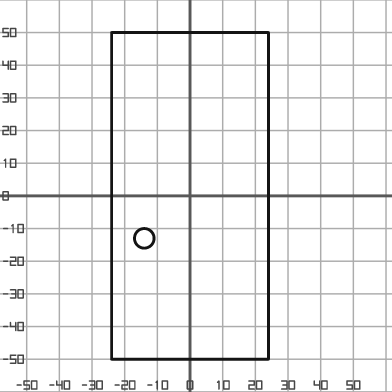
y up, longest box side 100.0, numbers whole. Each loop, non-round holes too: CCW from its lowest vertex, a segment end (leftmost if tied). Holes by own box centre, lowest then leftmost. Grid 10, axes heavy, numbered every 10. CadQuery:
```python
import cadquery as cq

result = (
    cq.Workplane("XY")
    .moveTo(-24.0, -50.0)
    .lineTo(24.0, -50.0)
    .lineTo(24.0, 50.0)
    .lineTo(-24.0, 50.0)
    .close()
    .moveTo(-14.0, -13.0)
    .circle(3.0)
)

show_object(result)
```